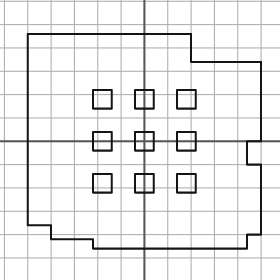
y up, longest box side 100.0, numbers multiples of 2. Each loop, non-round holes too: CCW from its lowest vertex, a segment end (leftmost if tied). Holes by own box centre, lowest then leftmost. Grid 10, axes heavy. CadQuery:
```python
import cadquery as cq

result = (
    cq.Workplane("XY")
    .moveTo(-22.0, -46.0)
    .lineTo(44.0, -46.0)
    .lineTo(44.0, -40.0)
    .lineTo(50.0, -40.0)
    .lineTo(50.0, -10.0)
    .lineTo(44.0, -10.0)
    .lineTo(44.0, 0.0)
    .lineTo(50.0, 0.0)
    .lineTo(50.0, 34.0)
    .lineTo(20.0, 34.0)
    .lineTo(20.0, 46.0)
    .lineTo(-50.0, 46.0)
    .lineTo(-50.0, -36.0)
    .lineTo(-40.0, -36.0)
    .lineTo(-40.0, -42.0)
    .lineTo(-22.0, -42.0)
    .close()
    .moveTo(-22.0, -22.0)
    .lineTo(-14.0, -22.0)
    .lineTo(-14.0, -14.0)
    .lineTo(-22.0, -14.0)
    .close()
    .moveTo(-4.0, -22.0)
    .lineTo(4.0, -22.0)
    .lineTo(4.0, -14.0)
    .lineTo(-4.0, -14.0)
    .close()
    .moveTo(14.0, -22.0)
    .lineTo(22.0, -22.0)
    .lineTo(22.0, -14.0)
    .lineTo(14.0, -14.0)
    .close()
    .moveTo(-22.0, -4.0)
    .lineTo(-14.0, -4.0)
    .lineTo(-14.0, 4.0)
    .lineTo(-22.0, 4.0)
    .close()
    .moveTo(-4.0, -4.0)
    .lineTo(4.0, -4.0)
    .lineTo(4.0, 4.0)
    .lineTo(-4.0, 4.0)
    .close()
    .moveTo(14.0, -4.0)
    .lineTo(22.0, -4.0)
    .lineTo(22.0, 4.0)
    .lineTo(14.0, 4.0)
    .close()
    .moveTo(-22.0, 14.0)
    .lineTo(-14.0, 14.0)
    .lineTo(-14.0, 22.0)
    .lineTo(-22.0, 22.0)
    .close()
    .moveTo(-4.0, 14.0)
    .lineTo(4.0, 14.0)
    .lineTo(4.0, 22.0)
    .lineTo(-4.0, 22.0)
    .close()
    .moveTo(14.0, 14.0)
    .lineTo(22.0, 14.0)
    .lineTo(22.0, 22.0)
    .lineTo(14.0, 22.0)
    .close()
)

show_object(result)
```